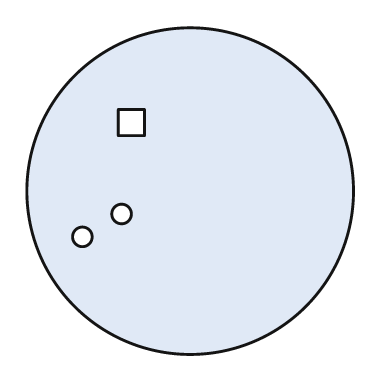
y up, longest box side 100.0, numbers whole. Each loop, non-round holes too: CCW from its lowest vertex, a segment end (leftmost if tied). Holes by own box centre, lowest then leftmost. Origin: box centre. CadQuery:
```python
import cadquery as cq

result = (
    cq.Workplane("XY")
    .moveTo(0.0, 0.0)
    .circle(50.0)
    .moveTo(-33.0, -14.0)
    .circle(3.0)
    .moveTo(-21.0, -7.0)
    .circle(3.0)
    .moveTo(-22.0, 17.0)
    .lineTo(-14.0, 17.0)
    .lineTo(-14.0, 25.0)
    .lineTo(-22.0, 25.0)
    .close()
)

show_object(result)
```